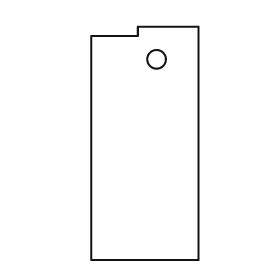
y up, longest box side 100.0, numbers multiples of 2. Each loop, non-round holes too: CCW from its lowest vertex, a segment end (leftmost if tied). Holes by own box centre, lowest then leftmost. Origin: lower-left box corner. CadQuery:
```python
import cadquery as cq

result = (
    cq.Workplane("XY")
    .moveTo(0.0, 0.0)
    .lineTo(46.0, 0.0)
    .lineTo(46.0, 100.0)
    .lineTo(20.0, 100.0)
    .lineTo(20.0, 96.0)
    .lineTo(0.0, 96.0)
    .close()
    .moveTo(28.0, 86.0)
    .circle(4.0)
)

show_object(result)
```